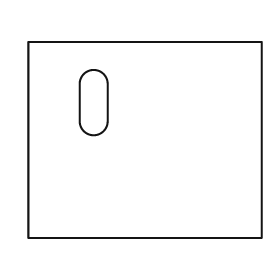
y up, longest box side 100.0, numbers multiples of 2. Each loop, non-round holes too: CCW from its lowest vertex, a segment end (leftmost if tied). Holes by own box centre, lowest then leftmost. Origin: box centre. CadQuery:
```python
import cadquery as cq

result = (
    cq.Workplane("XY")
    .moveTo(-50.0, -42.0)
    .lineTo(50.0, -42.0)
    .lineTo(50.0, 42.0)
    .lineTo(-50.0, 42.0)
    .close()
    .moveTo(-28.0, 8.0)
    .threePointArc((-22.0, 2.0), (-16.0, 8.0))
    .lineTo(-16.0, 24.0)
    .threePointArc((-22.0, 30.0), (-28.0, 24.0))
    .close()
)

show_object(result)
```